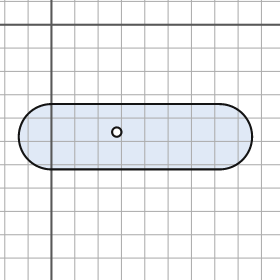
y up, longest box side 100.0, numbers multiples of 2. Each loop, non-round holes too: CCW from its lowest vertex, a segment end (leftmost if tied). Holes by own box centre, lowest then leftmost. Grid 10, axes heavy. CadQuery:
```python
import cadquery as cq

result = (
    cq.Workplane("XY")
    .moveTo(0.0, -62.0)
    .lineTo(72.0, -62.0)
    .threePointArc((86.0, -48.0), (72.0, -34.0))
    .lineTo(0.0, -34.0)
    .threePointArc((-14.0, -48.0), (0.0, -62.0))
    .close()
    .moveTo(28.0, -46.0)
    .circle(2.0)
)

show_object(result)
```